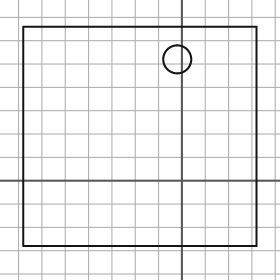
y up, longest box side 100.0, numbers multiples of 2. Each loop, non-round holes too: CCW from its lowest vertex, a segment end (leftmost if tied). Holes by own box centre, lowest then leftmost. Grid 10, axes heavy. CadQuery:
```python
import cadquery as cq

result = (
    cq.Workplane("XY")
    .moveTo(-68.0, -28.0)
    .lineTo(32.0, -28.0)
    .lineTo(32.0, 66.0)
    .lineTo(-68.0, 66.0)
    .close()
    .moveTo(-2.0, 52.0)
    .circle(6.0)
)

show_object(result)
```